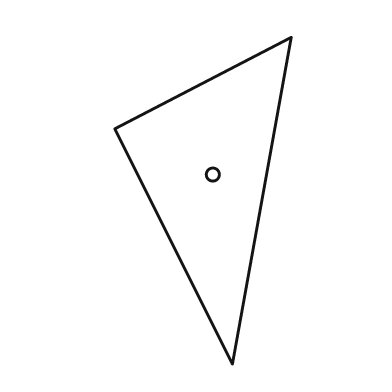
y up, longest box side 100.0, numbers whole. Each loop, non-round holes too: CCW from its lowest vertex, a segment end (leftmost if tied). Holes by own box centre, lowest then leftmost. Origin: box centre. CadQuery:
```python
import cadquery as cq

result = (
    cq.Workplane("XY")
    .moveTo(9.0, -50.0)
    .lineTo(27.0, 50.0)
    .lineTo(-27.0, 22.0)
    .close()
    .moveTo(3.0, 8.0)
    .circle(2.0)
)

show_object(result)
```